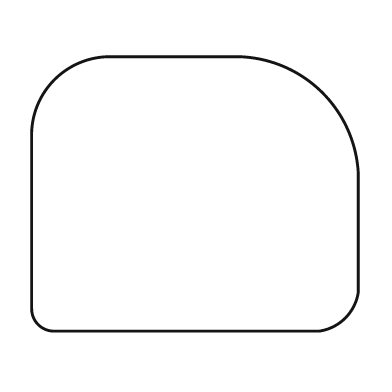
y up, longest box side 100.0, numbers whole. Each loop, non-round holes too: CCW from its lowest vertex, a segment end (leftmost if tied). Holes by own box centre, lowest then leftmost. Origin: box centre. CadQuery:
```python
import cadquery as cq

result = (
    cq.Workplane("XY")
    .moveTo(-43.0, -42.0)
    .lineTo(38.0, -42.0)
    .threePointArc((46.0, -38.0), (50.0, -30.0))
    .lineTo(50.0, 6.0)
    .threePointArc((39.0, 31.0), (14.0, 42.0))
    .lineTo(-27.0, 42.0)
    .threePointArc((-43.0, 35.0), (-50.0, 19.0))
    .lineTo(-50.0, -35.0)
    .threePointArc((-48.0, -40.0), (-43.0, -42.0))
    .close()
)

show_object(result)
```